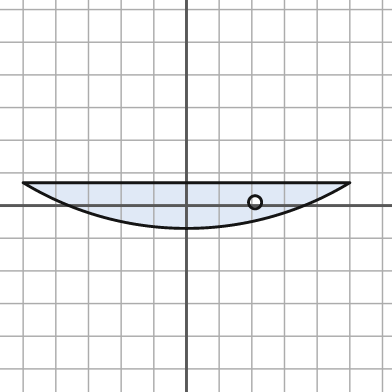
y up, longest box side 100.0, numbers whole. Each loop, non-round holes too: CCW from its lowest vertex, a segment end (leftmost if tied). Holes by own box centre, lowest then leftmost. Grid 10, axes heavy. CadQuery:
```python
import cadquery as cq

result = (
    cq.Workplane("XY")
    .moveTo(-50.0, 7.0)
    .threePointArc((0.0, -7.0), (50.0, 7.0))
    .close()
    .moveTo(21.0, 1.0)
    .circle(2.0)
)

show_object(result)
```